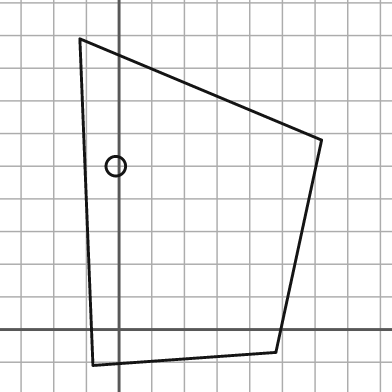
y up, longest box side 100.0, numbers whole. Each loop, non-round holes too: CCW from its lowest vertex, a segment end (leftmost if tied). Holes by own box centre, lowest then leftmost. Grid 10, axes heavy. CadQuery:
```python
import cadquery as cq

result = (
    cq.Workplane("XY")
    .moveTo(-8.0, -11.0)
    .lineTo(48.0, -7.0)
    .lineTo(62.0, 58.0)
    .lineTo(-12.0, 89.0)
    .close()
    .moveTo(-1.0, 50.0)
    .circle(3.0)
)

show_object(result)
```